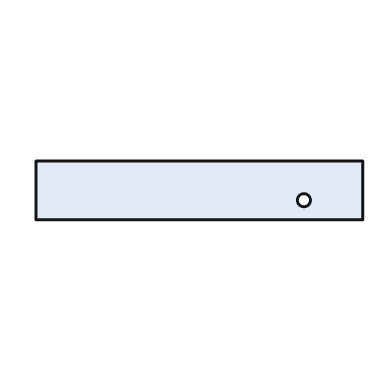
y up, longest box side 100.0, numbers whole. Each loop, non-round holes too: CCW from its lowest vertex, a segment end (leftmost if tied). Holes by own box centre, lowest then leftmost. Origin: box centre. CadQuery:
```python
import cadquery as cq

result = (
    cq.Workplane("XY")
    .moveTo(-50.0, -9.0)
    .lineTo(50.0, -9.0)
    .lineTo(50.0, 9.0)
    .lineTo(-50.0, 9.0)
    .close()
    .moveTo(32.0, -3.0)
    .circle(2.0)
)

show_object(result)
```